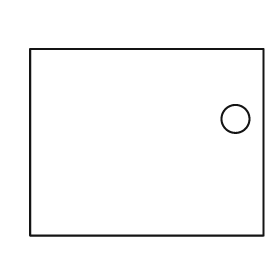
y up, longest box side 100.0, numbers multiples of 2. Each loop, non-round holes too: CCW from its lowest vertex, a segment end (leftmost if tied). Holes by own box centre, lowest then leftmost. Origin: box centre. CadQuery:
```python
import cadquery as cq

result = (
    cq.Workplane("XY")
    .moveTo(-50.0, -40.0)
    .lineTo(50.0, -40.0)
    .lineTo(50.0, 40.0)
    .lineTo(-50.0, 40.0)
    .close()
    .moveTo(38.0, 10.0)
    .circle(6.0)
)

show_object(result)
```